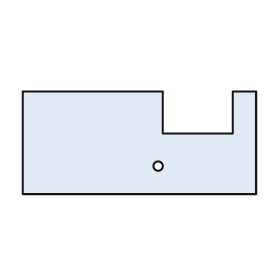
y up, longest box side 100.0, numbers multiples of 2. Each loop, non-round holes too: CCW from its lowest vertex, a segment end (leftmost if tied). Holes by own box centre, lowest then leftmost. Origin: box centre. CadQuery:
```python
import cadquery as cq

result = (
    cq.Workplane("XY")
    .moveTo(-50.0, -22.0)
    .lineTo(50.0, -22.0)
    .lineTo(50.0, 22.0)
    .lineTo(40.0, 22.0)
    .lineTo(40.0, 4.0)
    .lineTo(10.0, 4.0)
    .lineTo(10.0, 22.0)
    .lineTo(-50.0, 22.0)
    .close()
    .moveTo(8.0, -10.0)
    .circle(2.0)
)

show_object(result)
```